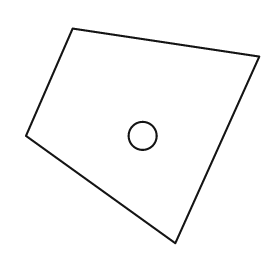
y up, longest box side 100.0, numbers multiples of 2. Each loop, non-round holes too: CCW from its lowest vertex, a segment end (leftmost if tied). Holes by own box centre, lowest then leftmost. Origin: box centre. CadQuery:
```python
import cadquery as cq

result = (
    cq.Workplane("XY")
    .moveTo(14.0, -46.0)
    .lineTo(50.0, 34.0)
    .lineTo(-30.0, 46.0)
    .lineTo(-50.0, 0.0)
    .close()
    .moveTo(0.0, 0.0)
    .circle(6.0)
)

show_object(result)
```